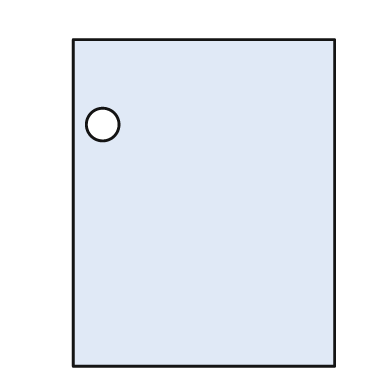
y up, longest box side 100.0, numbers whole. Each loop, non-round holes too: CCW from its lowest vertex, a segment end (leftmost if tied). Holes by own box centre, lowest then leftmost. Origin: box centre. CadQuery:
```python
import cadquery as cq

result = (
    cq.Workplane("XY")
    .moveTo(-40.0, -50.0)
    .lineTo(40.0, -50.0)
    .lineTo(40.0, 50.0)
    .lineTo(-40.0, 50.0)
    .close()
    .moveTo(-31.0, 24.0)
    .circle(5.0)
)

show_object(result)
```